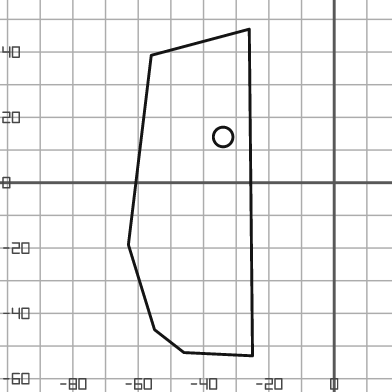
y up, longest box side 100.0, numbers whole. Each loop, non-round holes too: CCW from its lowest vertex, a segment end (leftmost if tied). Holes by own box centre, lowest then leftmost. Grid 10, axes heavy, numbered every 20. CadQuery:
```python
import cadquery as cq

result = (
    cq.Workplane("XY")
    .moveTo(-25.0, -53.0)
    .lineTo(-26.0, 47.0)
    .lineTo(-56.0, 39.0)
    .lineTo(-63.0, -19.0)
    .lineTo(-55.0, -45.0)
    .lineTo(-46.0, -52.0)
    .close()
    .moveTo(-34.0, 14.0)
    .circle(3.0)
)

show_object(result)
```